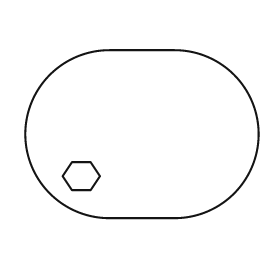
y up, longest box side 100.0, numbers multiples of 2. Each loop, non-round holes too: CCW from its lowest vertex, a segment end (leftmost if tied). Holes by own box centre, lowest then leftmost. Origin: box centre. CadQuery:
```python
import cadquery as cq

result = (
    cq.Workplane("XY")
    .moveTo(-14.0, -36.0)
    .lineTo(14.0, -36.0)
    .threePointArc((50.0, 0.0), (14.0, 36.0))
    .lineTo(-14.0, 36.0)
    .threePointArc((-50.0, 0.0), (-14.0, -36.0))
    .close()
    .moveTo(-30.0, -24.0)
    .lineTo(-22.0, -24.0)
    .lineTo(-18.0, -18.0)
    .lineTo(-22.0, -12.0)
    .lineTo(-30.0, -12.0)
    .lineTo(-34.0, -18.0)
    .close()
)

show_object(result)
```